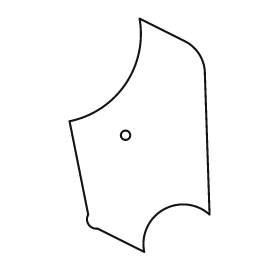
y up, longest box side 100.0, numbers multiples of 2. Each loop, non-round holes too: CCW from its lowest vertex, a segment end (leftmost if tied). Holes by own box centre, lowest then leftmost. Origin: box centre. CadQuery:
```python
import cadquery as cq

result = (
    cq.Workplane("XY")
    .moveTo(2.0, -50.0)
    .threePointArc((10.0, -32.0), (30.0, -34.0))
    .lineTo(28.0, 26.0)
    .threePointArc((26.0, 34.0), (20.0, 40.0))
    .lineTo(0.0, 50.0)
    .threePointArc((-6.0, 22.0), (-30.0, 6.0))
    .lineTo(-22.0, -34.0)
    .threePointArc((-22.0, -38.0), (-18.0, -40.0))
    .close()
    .moveTo(-6.0, 0.0)
    .circle(2.0)
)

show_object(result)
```